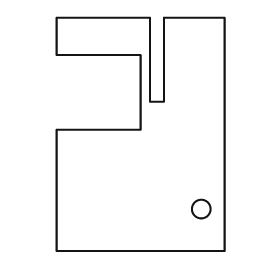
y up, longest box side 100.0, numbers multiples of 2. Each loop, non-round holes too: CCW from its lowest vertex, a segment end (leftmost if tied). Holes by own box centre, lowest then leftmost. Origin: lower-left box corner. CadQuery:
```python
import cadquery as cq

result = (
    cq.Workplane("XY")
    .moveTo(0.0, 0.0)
    .lineTo(72.0, 0.0)
    .lineTo(72.0, 100.0)
    .lineTo(46.0, 100.0)
    .lineTo(46.0, 64.0)
    .lineTo(40.0, 64.0)
    .lineTo(40.0, 100.0)
    .lineTo(0.0, 100.0)
    .lineTo(0.0, 84.0)
    .lineTo(36.0, 84.0)
    .lineTo(36.0, 52.0)
    .lineTo(0.0, 52.0)
    .close()
    .moveTo(62.0, 18.0)
    .circle(4.0)
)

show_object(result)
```